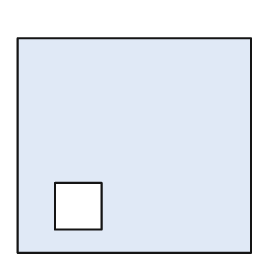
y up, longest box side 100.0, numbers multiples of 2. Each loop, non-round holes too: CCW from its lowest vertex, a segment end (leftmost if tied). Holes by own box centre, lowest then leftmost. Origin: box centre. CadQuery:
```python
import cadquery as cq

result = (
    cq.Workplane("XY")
    .moveTo(-50.0, -46.0)
    .lineTo(50.0, -46.0)
    .lineTo(50.0, 46.0)
    .lineTo(-50.0, 46.0)
    .close()
    .moveTo(-34.0, -36.0)
    .lineTo(-14.0, -36.0)
    .lineTo(-14.0, -16.0)
    .lineTo(-34.0, -16.0)
    .close()
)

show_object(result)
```